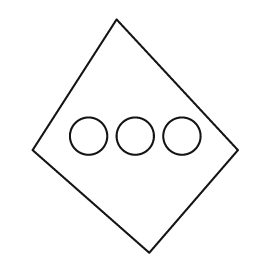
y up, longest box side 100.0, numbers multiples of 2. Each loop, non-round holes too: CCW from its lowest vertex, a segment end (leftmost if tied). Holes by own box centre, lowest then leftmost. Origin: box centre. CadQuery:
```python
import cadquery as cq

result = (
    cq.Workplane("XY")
    .moveTo(6.0, -50.0)
    .lineTo(44.0, -6.0)
    .lineTo(-8.0, 50.0)
    .lineTo(-44.0, -6.0)
    .close()
    .moveTo(-20.0, 0.0)
    .circle(8.0)
    .moveTo(0.0, 0.0)
    .circle(8.0)
    .moveTo(20.0, 0.0)
    .circle(8.0)
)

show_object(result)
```